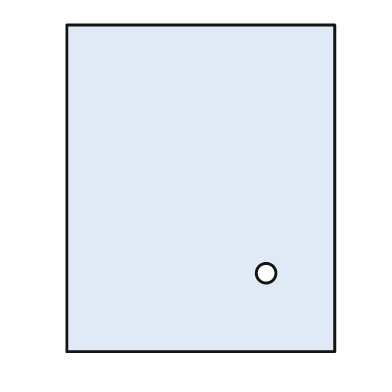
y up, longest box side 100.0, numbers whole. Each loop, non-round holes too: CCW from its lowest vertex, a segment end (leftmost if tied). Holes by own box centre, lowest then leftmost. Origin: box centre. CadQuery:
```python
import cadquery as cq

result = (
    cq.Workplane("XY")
    .moveTo(-41.0, -50.0)
    .lineTo(41.0, -50.0)
    .lineTo(41.0, 50.0)
    .lineTo(-41.0, 50.0)
    .close()
    .moveTo(20.0, -26.0)
    .circle(3.0)
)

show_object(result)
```